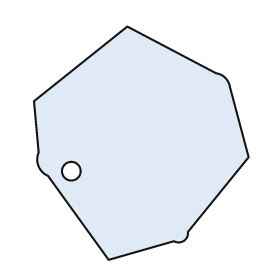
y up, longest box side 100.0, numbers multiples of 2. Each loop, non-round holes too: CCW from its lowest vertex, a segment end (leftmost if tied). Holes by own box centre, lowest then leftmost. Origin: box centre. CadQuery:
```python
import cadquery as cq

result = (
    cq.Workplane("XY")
    .moveTo(-14.0, -50.0)
    .lineTo(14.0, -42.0)
    .threePointArc((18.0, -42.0), (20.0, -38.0))
    .lineTo(46.0, -6.0)
    .lineTo(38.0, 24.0)
    .threePointArc((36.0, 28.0), (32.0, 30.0))
    .lineTo(-6.0, 50.0)
    .lineTo(-46.0, 18.0)
    .lineTo(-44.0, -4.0)
    .threePointArc((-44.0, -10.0), (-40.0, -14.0))
    .close()
    .moveTo(-30.0, -12.0)
    .circle(4.0)
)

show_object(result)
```